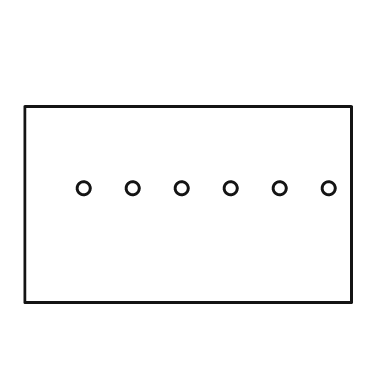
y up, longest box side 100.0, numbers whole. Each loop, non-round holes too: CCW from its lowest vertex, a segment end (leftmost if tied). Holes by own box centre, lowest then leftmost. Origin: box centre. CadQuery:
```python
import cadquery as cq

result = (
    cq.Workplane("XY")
    .moveTo(-50.0, -30.0)
    .lineTo(50.0, -30.0)
    .lineTo(50.0, 30.0)
    .lineTo(-50.0, 30.0)
    .close()
    .moveTo(-32.0, 5.0)
    .circle(2.0)
    .moveTo(-17.0, 5.0)
    .circle(2.0)
    .moveTo(-2.0, 5.0)
    .circle(2.0)
    .moveTo(13.0, 5.0)
    .circle(2.0)
    .moveTo(28.0, 5.0)
    .circle(2.0)
    .moveTo(43.0, 5.0)
    .circle(2.0)
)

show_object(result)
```